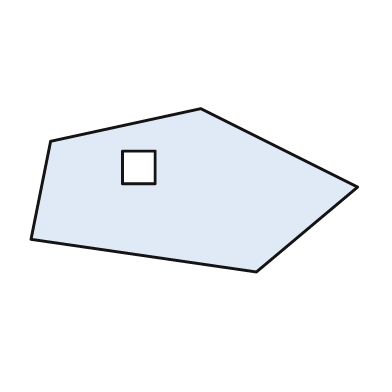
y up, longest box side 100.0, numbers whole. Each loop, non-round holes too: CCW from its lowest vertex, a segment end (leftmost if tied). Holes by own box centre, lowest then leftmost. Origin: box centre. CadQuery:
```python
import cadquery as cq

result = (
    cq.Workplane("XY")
    .moveTo(19.0, -25.0)
    .lineTo(50.0, 1.0)
    .lineTo(2.0, 25.0)
    .lineTo(-44.0, 15.0)
    .lineTo(-50.0, -15.0)
    .close()
    .moveTo(-22.0, 2.0)
    .lineTo(-12.0, 2.0)
    .lineTo(-12.0, 12.0)
    .lineTo(-22.0, 12.0)
    .close()
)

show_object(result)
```